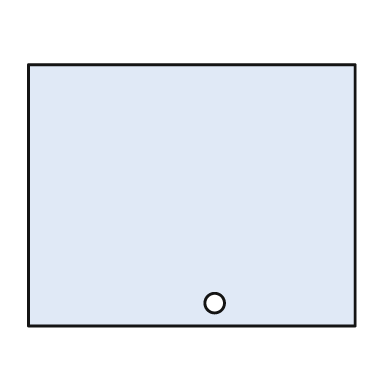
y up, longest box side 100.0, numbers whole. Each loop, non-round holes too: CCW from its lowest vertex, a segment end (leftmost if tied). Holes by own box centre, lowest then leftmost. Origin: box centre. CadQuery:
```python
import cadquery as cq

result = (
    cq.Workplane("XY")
    .moveTo(-50.0, -40.0)
    .lineTo(50.0, -40.0)
    .lineTo(50.0, 40.0)
    .lineTo(-50.0, 40.0)
    .close()
    .moveTo(7.0, -33.0)
    .circle(3.0)
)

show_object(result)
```